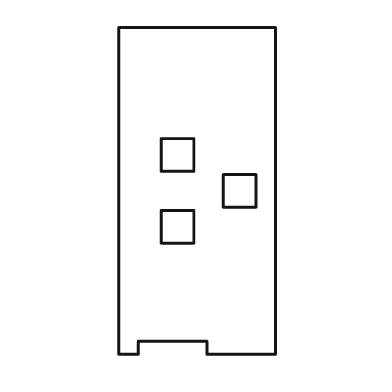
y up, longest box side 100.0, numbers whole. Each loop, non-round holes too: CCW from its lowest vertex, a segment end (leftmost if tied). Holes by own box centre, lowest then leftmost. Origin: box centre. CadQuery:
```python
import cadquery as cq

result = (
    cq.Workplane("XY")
    .moveTo(-24.0, -50.0)
    .lineTo(-18.0, -50.0)
    .lineTo(-18.0, -46.0)
    .lineTo(3.0, -46.0)
    .lineTo(3.0, -50.0)
    .lineTo(24.0, -50.0)
    .lineTo(24.0, 50.0)
    .lineTo(-24.0, 50.0)
    .close()
    .moveTo(-11.0, -16.0)
    .lineTo(-1.0, -16.0)
    .lineTo(-1.0, -6.0)
    .lineTo(-11.0, -6.0)
    .close()
    .moveTo(8.0, -5.0)
    .lineTo(18.0, -5.0)
    .lineTo(18.0, 5.0)
    .lineTo(8.0, 5.0)
    .close()
    .moveTo(-11.0, 6.0)
    .lineTo(-1.0, 6.0)
    .lineTo(-1.0, 16.0)
    .lineTo(-11.0, 16.0)
    .close()
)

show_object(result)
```